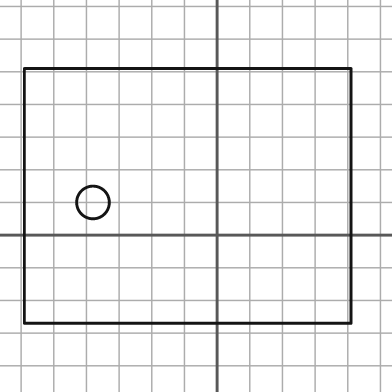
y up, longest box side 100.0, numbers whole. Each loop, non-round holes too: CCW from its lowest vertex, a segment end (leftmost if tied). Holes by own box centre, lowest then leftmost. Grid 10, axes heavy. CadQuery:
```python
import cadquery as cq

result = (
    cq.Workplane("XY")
    .moveTo(-59.0, -27.0)
    .lineTo(41.0, -27.0)
    .lineTo(41.0, 51.0)
    .lineTo(-59.0, 51.0)
    .close()
    .moveTo(-38.0, 10.0)
    .circle(5.0)
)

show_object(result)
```